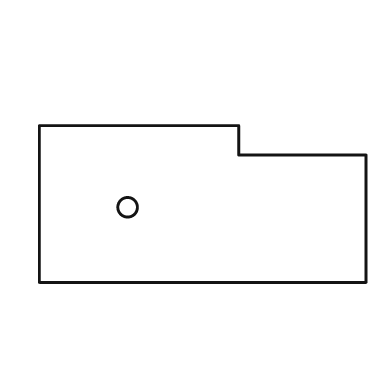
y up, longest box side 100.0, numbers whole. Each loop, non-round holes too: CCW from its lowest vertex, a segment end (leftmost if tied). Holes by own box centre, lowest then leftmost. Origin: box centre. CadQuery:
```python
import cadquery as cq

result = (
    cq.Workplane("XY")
    .moveTo(-50.0, -24.0)
    .lineTo(50.0, -24.0)
    .lineTo(50.0, 15.0)
    .lineTo(11.0, 15.0)
    .lineTo(11.0, 24.0)
    .lineTo(-50.0, 24.0)
    .close()
    .moveTo(-23.0, -1.0)
    .circle(3.0)
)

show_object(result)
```